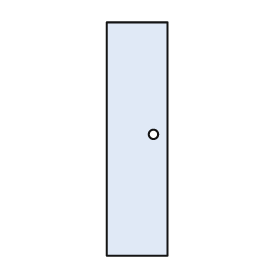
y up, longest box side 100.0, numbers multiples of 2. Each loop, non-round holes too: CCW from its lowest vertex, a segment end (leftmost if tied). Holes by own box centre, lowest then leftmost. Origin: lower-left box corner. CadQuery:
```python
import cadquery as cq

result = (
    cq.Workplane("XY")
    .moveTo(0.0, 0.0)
    .lineTo(26.0, 0.0)
    .lineTo(26.0, 100.0)
    .lineTo(0.0, 100.0)
    .close()
    .moveTo(20.0, 52.0)
    .circle(2.0)
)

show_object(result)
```